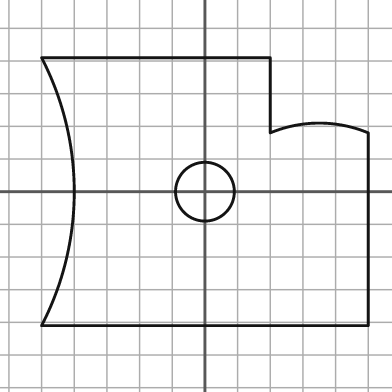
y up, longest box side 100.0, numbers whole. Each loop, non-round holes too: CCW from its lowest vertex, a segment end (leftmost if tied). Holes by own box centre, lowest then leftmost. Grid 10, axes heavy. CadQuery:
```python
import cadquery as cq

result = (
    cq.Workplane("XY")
    .moveTo(-50.0, -41.0)
    .lineTo(50.0, -41.0)
    .lineTo(50.0, 18.0)
    .threePointArc((35.0, 21.0), (20.0, 18.0))
    .lineTo(20.0, 41.0)
    .lineTo(-50.0, 41.0)
    .threePointArc((-40.0, 0.0), (-50.0, -41.0))
    .close()
    .moveTo(0.0, 0.0)
    .circle(9.0)
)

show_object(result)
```